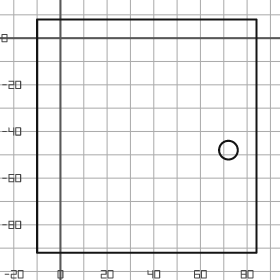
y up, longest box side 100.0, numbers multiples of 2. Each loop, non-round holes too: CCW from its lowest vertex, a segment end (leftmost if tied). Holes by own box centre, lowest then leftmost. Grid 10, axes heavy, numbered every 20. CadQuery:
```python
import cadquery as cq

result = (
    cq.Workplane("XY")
    .moveTo(-10.0, -92.0)
    .lineTo(84.0, -92.0)
    .lineTo(84.0, 8.0)
    .lineTo(-10.0, 8.0)
    .close()
    .moveTo(72.0, -48.0)
    .circle(4.0)
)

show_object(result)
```